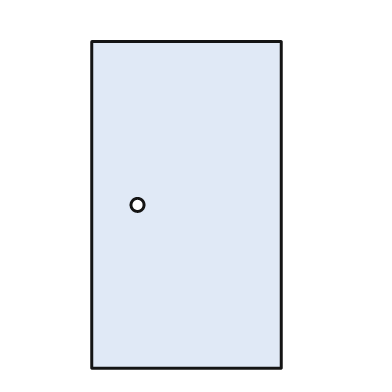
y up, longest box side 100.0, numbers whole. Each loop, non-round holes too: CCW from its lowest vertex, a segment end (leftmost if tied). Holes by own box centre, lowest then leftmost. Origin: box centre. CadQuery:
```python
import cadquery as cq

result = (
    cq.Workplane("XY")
    .moveTo(-29.0, -50.0)
    .lineTo(29.0, -50.0)
    .lineTo(29.0, 50.0)
    .lineTo(-29.0, 50.0)
    .close()
    .moveTo(-15.0, 0.0)
    .circle(2.0)
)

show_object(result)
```